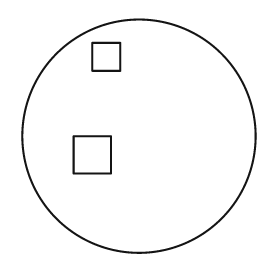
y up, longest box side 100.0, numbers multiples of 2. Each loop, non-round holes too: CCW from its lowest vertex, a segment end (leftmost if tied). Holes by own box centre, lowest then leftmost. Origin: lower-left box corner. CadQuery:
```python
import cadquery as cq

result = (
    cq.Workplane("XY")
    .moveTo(50.0, 50.0)
    .circle(50.0)
    .moveTo(22.0, 34.0)
    .lineTo(38.0, 34.0)
    .lineTo(38.0, 50.0)
    .lineTo(22.0, 50.0)
    .close()
    .moveTo(30.0, 78.0)
    .lineTo(42.0, 78.0)
    .lineTo(42.0, 90.0)
    .lineTo(30.0, 90.0)
    .close()
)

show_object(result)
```